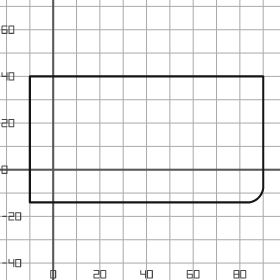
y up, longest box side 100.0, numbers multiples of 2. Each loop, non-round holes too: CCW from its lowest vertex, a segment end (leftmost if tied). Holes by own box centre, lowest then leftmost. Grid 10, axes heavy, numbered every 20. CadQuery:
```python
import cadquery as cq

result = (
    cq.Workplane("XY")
    .moveTo(-10.0, -14.0)
    .lineTo(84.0, -14.0)
    .threePointArc((88.0, -12.0), (90.0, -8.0))
    .lineTo(90.0, 40.0)
    .lineTo(-10.0, 40.0)
    .close()
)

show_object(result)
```